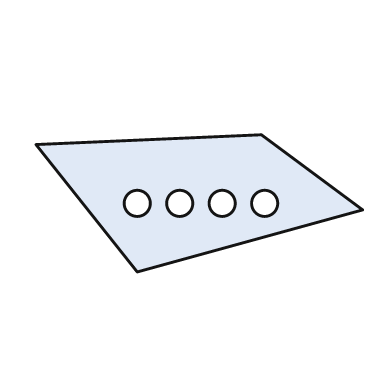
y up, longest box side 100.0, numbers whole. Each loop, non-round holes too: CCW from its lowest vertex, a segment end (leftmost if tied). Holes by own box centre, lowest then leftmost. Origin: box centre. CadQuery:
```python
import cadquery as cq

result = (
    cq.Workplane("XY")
    .moveTo(-19.0, -21.0)
    .lineTo(50.0, -2.0)
    .lineTo(19.0, 21.0)
    .lineTo(-50.0, 18.0)
    .close()
    .moveTo(-19.0, 0.0)
    .circle(4.0)
    .moveTo(-6.0, 0.0)
    .circle(4.0)
    .moveTo(7.0, 0.0)
    .circle(4.0)
    .moveTo(20.0, 0.0)
    .circle(4.0)
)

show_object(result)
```